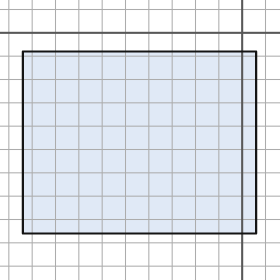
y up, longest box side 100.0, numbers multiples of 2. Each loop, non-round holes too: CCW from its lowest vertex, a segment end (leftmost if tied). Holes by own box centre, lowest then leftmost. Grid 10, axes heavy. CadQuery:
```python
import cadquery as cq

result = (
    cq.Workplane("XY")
    .moveTo(-94.0, -86.0)
    .lineTo(6.0, -86.0)
    .lineTo(6.0, -8.0)
    .lineTo(-94.0, -8.0)
    .close()
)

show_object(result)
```